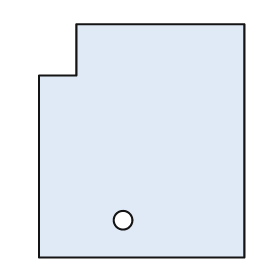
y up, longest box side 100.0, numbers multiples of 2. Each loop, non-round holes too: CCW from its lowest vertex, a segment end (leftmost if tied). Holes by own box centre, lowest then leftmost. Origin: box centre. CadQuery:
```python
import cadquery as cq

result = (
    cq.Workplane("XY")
    .moveTo(-44.0, -50.0)
    .lineTo(44.0, -50.0)
    .lineTo(44.0, 50.0)
    .lineTo(-28.0, 50.0)
    .lineTo(-28.0, 28.0)
    .lineTo(-44.0, 28.0)
    .close()
    .moveTo(-8.0, -34.0)
    .circle(4.0)
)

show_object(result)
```